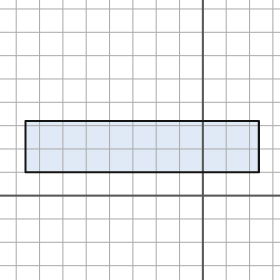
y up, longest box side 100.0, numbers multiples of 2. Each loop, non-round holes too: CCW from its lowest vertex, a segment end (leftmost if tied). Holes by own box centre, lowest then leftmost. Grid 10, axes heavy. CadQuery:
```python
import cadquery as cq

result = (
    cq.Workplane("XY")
    .moveTo(-76.0, 10.0)
    .lineTo(24.0, 10.0)
    .lineTo(24.0, 32.0)
    .lineTo(-76.0, 32.0)
    .close()
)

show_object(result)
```